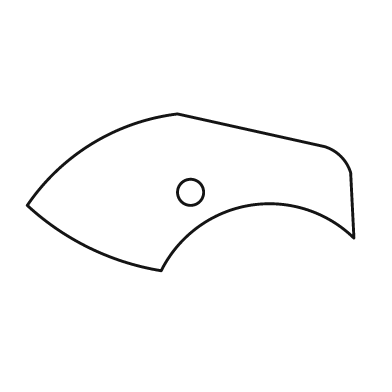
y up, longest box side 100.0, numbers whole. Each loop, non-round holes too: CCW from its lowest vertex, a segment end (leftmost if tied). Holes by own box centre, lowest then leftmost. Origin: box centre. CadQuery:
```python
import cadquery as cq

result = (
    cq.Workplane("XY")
    .moveTo(-9.0, -24.0)
    .threePointArc((18.0, -4.0), (50.0, -14.0))
    .lineTo(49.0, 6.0)
    .threePointArc((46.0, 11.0), (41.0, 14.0))
    .lineTo(-4.0, 24.0)
    .threePointArc((-30.0, 15.0), (-50.0, -4.0))
    .threePointArc((-31.0, -17.0), (-9.0, -24.0))
    .close()
    .moveTo(0.0, 0.0)
    .circle(4.0)
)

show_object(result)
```